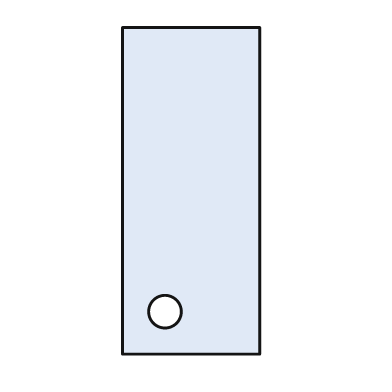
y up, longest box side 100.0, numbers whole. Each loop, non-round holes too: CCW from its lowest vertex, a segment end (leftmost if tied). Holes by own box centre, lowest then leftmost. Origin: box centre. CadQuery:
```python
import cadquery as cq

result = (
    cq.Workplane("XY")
    .moveTo(-21.0, -50.0)
    .lineTo(21.0, -50.0)
    .lineTo(21.0, 50.0)
    .lineTo(-21.0, 50.0)
    .close()
    .moveTo(-8.0, -37.0)
    .circle(5.0)
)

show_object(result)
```